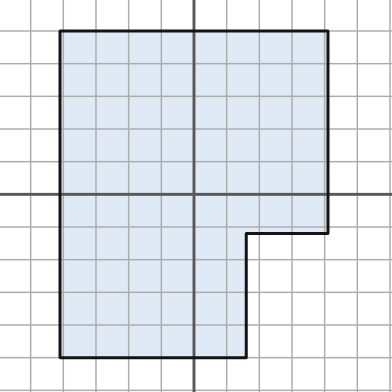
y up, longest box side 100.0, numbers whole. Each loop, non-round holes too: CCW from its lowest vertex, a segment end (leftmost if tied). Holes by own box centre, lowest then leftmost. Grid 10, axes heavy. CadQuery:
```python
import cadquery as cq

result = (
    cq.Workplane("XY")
    .moveTo(-41.0, -50.0)
    .lineTo(16.0, -50.0)
    .lineTo(16.0, -12.0)
    .lineTo(41.0, -12.0)
    .lineTo(41.0, 50.0)
    .lineTo(-41.0, 50.0)
    .close()
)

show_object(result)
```